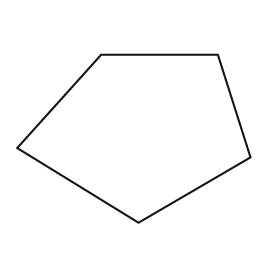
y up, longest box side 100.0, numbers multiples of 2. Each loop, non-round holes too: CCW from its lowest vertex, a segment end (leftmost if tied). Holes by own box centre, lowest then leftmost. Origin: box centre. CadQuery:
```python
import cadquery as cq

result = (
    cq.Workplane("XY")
    .moveTo(2.0, -36.0)
    .lineTo(50.0, -8.0)
    .lineTo(36.0, 36.0)
    .lineTo(-14.0, 36.0)
    .lineTo(-50.0, -4.0)
    .close()
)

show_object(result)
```